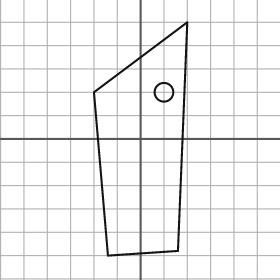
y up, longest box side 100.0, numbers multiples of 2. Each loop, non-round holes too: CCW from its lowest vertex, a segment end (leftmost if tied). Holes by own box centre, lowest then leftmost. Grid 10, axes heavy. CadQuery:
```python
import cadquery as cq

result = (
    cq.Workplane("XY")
    .moveTo(-14.0, -50.0)
    .lineTo(16.0, -48.0)
    .lineTo(20.0, 50.0)
    .lineTo(-20.0, 20.0)
    .close()
    .moveTo(10.0, 20.0)
    .circle(4.0)
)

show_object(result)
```